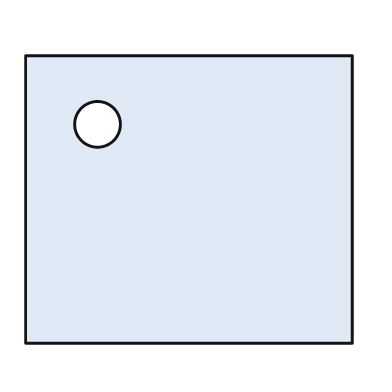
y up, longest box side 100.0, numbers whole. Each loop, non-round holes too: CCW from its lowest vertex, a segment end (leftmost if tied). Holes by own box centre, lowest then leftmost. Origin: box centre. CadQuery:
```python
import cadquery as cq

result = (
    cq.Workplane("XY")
    .moveTo(-50.0, -44.0)
    .lineTo(50.0, -44.0)
    .lineTo(50.0, 44.0)
    .lineTo(-50.0, 44.0)
    .close()
    .moveTo(-28.0, 23.0)
    .circle(7.0)
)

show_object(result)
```